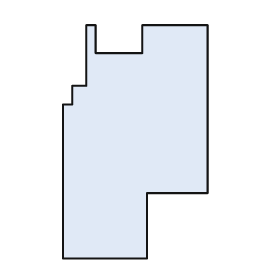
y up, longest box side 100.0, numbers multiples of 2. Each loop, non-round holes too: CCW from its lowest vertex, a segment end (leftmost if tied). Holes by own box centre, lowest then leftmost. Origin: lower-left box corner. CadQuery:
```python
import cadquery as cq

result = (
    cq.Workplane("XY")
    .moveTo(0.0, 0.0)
    .lineTo(36.0, 0.0)
    .lineTo(36.0, 28.0)
    .lineTo(62.0, 28.0)
    .lineTo(62.0, 100.0)
    .lineTo(34.0, 100.0)
    .lineTo(34.0, 88.0)
    .lineTo(14.0, 88.0)
    .lineTo(14.0, 100.0)
    .lineTo(10.0, 100.0)
    .lineTo(10.0, 74.0)
    .lineTo(4.0, 74.0)
    .lineTo(4.0, 66.0)
    .lineTo(0.0, 66.0)
    .close()
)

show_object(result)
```